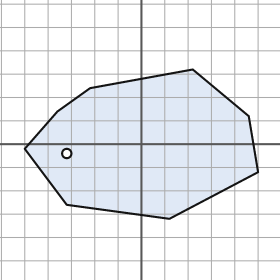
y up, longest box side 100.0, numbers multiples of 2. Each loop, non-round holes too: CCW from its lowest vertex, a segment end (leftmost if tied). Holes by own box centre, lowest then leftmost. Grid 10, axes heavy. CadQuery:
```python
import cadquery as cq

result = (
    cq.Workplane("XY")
    .moveTo(12.0, -32.0)
    .lineTo(50.0, -12.0)
    .lineTo(46.0, 12.0)
    .lineTo(22.0, 32.0)
    .lineTo(-22.0, 24.0)
    .lineTo(-36.0, 14.0)
    .lineTo(-50.0, -2.0)
    .lineTo(-32.0, -26.0)
    .close()
    .moveTo(-32.0, -4.0)
    .circle(2.0)
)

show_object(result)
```